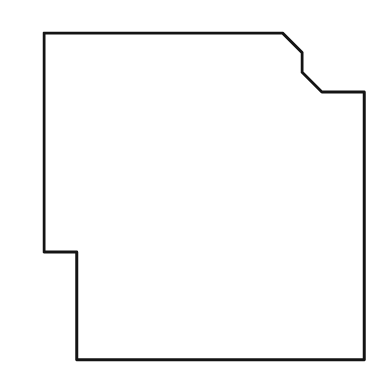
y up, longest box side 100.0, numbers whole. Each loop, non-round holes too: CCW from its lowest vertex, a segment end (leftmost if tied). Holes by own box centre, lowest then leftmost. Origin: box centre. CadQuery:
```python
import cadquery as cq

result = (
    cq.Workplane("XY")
    .moveTo(-39.0, -50.0)
    .lineTo(49.0, -50.0)
    .lineTo(49.0, 32.0)
    .lineTo(36.0, 32.0)
    .lineTo(30.0, 38.0)
    .lineTo(30.0, 44.0)
    .lineTo(24.0, 50.0)
    .lineTo(-49.0, 50.0)
    .lineTo(-49.0, -17.0)
    .lineTo(-39.0, -17.0)
    .close()
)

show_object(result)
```